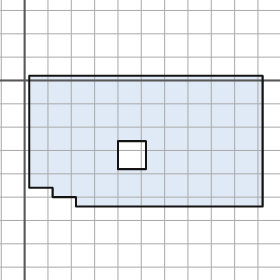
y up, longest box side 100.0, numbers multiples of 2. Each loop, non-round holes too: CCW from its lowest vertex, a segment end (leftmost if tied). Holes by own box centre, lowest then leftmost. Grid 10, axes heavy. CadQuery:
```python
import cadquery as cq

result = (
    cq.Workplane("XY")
    .moveTo(22.0, -54.0)
    .lineTo(102.0, -54.0)
    .lineTo(102.0, 2.0)
    .lineTo(2.0, 2.0)
    .lineTo(2.0, -46.0)
    .lineTo(12.0, -46.0)
    .lineTo(12.0, -50.0)
    .lineTo(22.0, -50.0)
    .close()
    .moveTo(40.0, -38.0)
    .lineTo(52.0, -38.0)
    .lineTo(52.0, -26.0)
    .lineTo(40.0, -26.0)
    .close()
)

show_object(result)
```